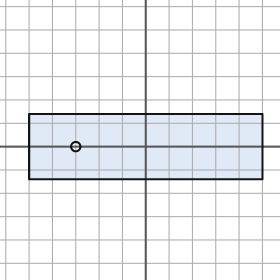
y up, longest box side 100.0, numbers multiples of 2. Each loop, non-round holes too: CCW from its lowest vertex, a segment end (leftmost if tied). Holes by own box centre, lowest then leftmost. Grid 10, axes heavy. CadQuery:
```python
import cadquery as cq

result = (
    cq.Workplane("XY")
    .moveTo(-50.0, -14.0)
    .lineTo(50.0, -14.0)
    .lineTo(50.0, 14.0)
    .lineTo(-50.0, 14.0)
    .close()
    .moveTo(-30.0, 0.0)
    .circle(2.0)
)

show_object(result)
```